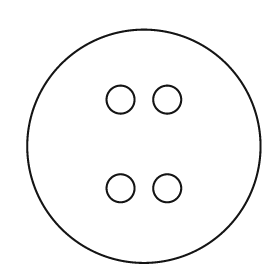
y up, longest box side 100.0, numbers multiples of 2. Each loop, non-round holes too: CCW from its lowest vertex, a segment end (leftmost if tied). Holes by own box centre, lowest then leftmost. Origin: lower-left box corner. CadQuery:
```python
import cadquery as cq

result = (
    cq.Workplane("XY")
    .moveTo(50.0, 50.0)
    .circle(50.0)
    .moveTo(40.0, 32.0)
    .circle(6.0)
    .moveTo(60.0, 32.0)
    .circle(6.0)
    .moveTo(40.0, 70.0)
    .circle(6.0)
    .moveTo(60.0, 70.0)
    .circle(6.0)
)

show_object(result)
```